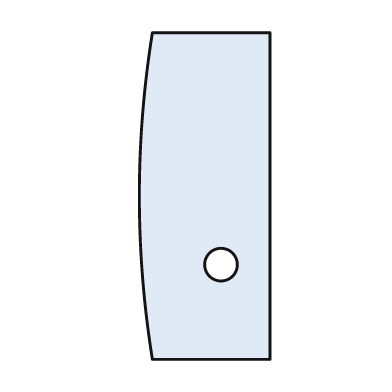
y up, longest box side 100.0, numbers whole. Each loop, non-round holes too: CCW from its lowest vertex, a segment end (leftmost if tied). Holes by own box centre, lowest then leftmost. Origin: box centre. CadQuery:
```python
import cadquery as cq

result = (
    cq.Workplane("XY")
    .moveTo(-16.0, -50.0)
    .lineTo(20.0, -50.0)
    .lineTo(20.0, 50.0)
    .lineTo(-16.0, 50.0)
    .threePointArc((-20.0, 0.0), (-16.0, -50.0))
    .close()
    .moveTo(5.0, -21.0)
    .circle(5.0)
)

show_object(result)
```